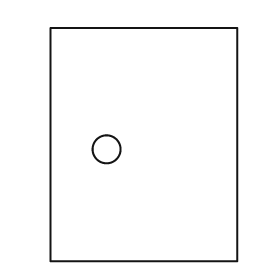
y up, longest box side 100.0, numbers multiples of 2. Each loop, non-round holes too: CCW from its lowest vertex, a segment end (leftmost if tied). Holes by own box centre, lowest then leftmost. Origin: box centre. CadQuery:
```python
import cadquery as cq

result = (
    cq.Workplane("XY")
    .moveTo(-40.0, -50.0)
    .lineTo(40.0, -50.0)
    .lineTo(40.0, 50.0)
    .lineTo(-40.0, 50.0)
    .close()
    .moveTo(-16.0, -2.0)
    .circle(6.0)
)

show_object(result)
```